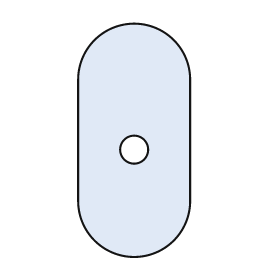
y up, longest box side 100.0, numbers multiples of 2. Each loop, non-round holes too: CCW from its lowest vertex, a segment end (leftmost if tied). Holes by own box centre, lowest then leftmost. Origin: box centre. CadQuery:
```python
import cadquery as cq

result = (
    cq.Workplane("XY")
    .moveTo(-24.0, -26.0)
    .threePointArc((0.0, -50.0), (24.0, -26.0))
    .lineTo(24.0, 26.0)
    .threePointArc((0.0, 50.0), (-24.0, 26.0))
    .close()
    .moveTo(0.0, -4.0)
    .circle(6.0)
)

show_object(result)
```